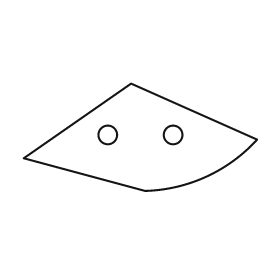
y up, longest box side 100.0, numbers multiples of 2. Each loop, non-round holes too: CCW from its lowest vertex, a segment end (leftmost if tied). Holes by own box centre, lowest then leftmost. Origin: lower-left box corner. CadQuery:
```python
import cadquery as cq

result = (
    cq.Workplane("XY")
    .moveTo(52.0, 0.0)
    .threePointArc((78.0, 6.0), (100.0, 22.0))
    .lineTo(46.0, 46.0)
    .lineTo(0.0, 14.0)
    .close()
    .moveTo(36.0, 24.0)
    .circle(4.0)
    .moveTo(64.0, 24.0)
    .circle(4.0)
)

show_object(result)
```